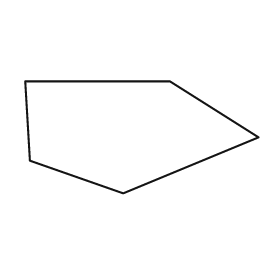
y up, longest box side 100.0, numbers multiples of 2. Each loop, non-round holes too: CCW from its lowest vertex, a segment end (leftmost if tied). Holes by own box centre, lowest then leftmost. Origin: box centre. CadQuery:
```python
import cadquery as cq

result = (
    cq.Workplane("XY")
    .moveTo(-8.0, -24.0)
    .lineTo(50.0, 0.0)
    .lineTo(12.0, 24.0)
    .lineTo(-50.0, 24.0)
    .lineTo(-48.0, -10.0)
    .close()
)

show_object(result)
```